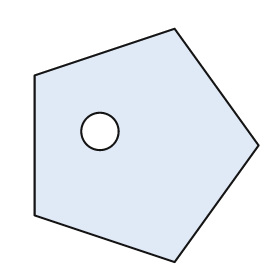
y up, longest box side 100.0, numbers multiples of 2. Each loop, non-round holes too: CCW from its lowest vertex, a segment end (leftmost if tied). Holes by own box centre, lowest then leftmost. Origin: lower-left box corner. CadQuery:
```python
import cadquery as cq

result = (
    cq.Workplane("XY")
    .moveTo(60.0, 0.0)
    .lineTo(96.0, 50.0)
    .lineTo(60.0, 100.0)
    .lineTo(0.0, 80.0)
    .lineTo(0.0, 20.0)
    .close()
    .moveTo(28.0, 56.0)
    .circle(8.0)
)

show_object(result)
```